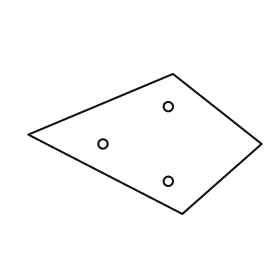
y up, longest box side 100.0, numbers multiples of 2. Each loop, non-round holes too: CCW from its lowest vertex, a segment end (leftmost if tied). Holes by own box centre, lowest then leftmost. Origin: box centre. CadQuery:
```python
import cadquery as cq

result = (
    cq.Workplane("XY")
    .moveTo(16.0, -30.0)
    .lineTo(50.0, 0.0)
    .lineTo(12.0, 30.0)
    .lineTo(-50.0, 4.0)
    .close()
    .moveTo(10.0, -16.0)
    .circle(2.0)
    .moveTo(-18.0, 0.0)
    .circle(2.0)
    .moveTo(10.0, 16.0)
    .circle(2.0)
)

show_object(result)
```